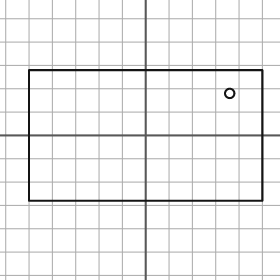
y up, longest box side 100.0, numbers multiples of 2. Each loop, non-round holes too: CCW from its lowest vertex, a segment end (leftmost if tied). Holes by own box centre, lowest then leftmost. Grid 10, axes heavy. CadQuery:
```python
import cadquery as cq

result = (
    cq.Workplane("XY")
    .moveTo(-50.0, -28.0)
    .lineTo(50.0, -28.0)
    .lineTo(50.0, 28.0)
    .lineTo(-50.0, 28.0)
    .close()
    .moveTo(36.0, 18.0)
    .circle(2.0)
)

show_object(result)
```